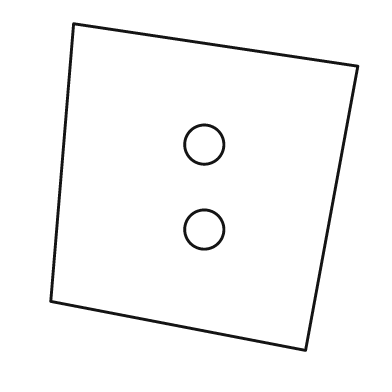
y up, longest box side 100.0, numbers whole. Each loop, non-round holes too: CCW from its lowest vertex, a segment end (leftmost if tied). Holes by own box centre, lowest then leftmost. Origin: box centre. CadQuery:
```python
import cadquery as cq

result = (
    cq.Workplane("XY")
    .moveTo(31.0, -50.0)
    .lineTo(47.0, 37.0)
    .lineTo(-40.0, 50.0)
    .lineTo(-47.0, -35.0)
    .close()
    .moveTo(0.0, -13.0)
    .circle(6.0)
    .moveTo(0.0, 13.0)
    .circle(6.0)
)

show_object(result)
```